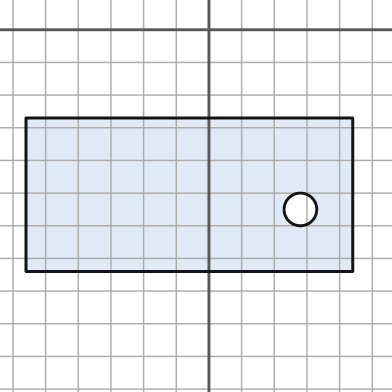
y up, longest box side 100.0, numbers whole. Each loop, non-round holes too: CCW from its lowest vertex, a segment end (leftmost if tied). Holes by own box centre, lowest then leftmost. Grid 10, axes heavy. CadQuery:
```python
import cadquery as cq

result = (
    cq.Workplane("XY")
    .moveTo(-56.0, -74.0)
    .lineTo(44.0, -74.0)
    .lineTo(44.0, -27.0)
    .lineTo(-56.0, -27.0)
    .close()
    .moveTo(28.0, -55.0)
    .circle(5.0)
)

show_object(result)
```